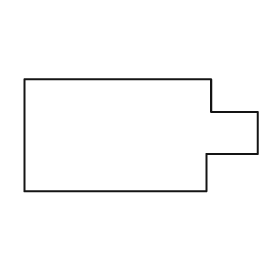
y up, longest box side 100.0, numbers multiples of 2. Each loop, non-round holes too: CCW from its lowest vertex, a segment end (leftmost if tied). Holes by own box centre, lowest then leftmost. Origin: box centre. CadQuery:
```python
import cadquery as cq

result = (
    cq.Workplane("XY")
    .moveTo(-50.0, -24.0)
    .lineTo(28.0, -24.0)
    .lineTo(28.0, -8.0)
    .lineTo(50.0, -8.0)
    .lineTo(50.0, 10.0)
    .lineTo(30.0, 10.0)
    .lineTo(30.0, 24.0)
    .lineTo(-50.0, 24.0)
    .close()
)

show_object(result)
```